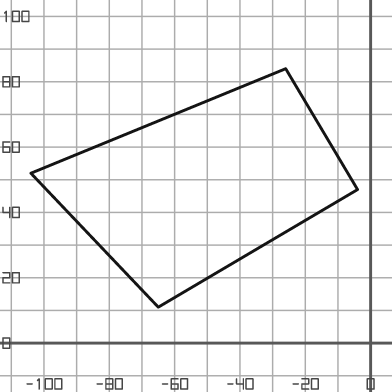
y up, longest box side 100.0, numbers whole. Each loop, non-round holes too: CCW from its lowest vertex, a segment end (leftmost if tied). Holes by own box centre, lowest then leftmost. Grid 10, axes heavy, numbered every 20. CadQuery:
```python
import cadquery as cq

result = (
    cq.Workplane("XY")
    .moveTo(-65.0, 11.0)
    .lineTo(-4.0, 47.0)
    .lineTo(-26.0, 84.0)
    .lineTo(-104.0, 52.0)
    .close()
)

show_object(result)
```